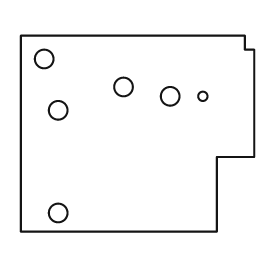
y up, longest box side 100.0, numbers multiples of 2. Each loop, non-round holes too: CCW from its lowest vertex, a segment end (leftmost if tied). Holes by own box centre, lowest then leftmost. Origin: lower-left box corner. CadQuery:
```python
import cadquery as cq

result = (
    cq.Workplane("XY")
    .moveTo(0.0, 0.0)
    .lineTo(84.0, 0.0)
    .lineTo(84.0, 32.0)
    .lineTo(100.0, 32.0)
    .lineTo(100.0, 78.0)
    .lineTo(96.0, 78.0)
    .lineTo(96.0, 84.0)
    .lineTo(0.0, 84.0)
    .close()
    .moveTo(16.0, 8.0)
    .circle(4.0)
    .moveTo(16.0, 52.0)
    .circle(4.0)
    .moveTo(64.0, 58.0)
    .circle(4.0)
    .moveTo(78.0, 58.0)
    .circle(2.0)
    .moveTo(44.0, 62.0)
    .circle(4.0)
    .moveTo(10.0, 74.0)
    .circle(4.0)
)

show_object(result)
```